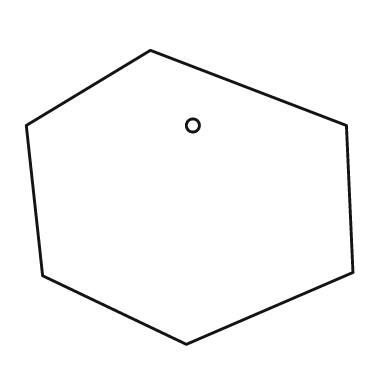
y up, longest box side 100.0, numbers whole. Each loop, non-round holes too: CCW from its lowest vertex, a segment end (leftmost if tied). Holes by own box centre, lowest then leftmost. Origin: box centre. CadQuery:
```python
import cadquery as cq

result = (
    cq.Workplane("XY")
    .moveTo(-1.0, -45.0)
    .lineTo(50.0, -23.0)
    .lineTo(48.0, 22.0)
    .lineTo(-12.0, 45.0)
    .lineTo(-50.0, 22.0)
    .lineTo(-45.0, -24.0)
    .close()
    .moveTo(1.0, 22.0)
    .circle(2.0)
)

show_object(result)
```